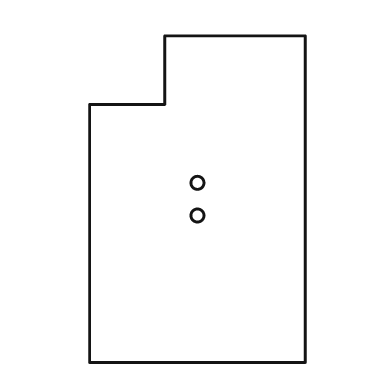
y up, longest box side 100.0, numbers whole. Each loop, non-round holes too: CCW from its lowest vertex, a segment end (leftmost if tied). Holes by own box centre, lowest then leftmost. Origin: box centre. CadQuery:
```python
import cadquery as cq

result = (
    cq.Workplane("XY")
    .moveTo(-33.0, -50.0)
    .lineTo(33.0, -50.0)
    .lineTo(33.0, 50.0)
    .lineTo(-10.0, 50.0)
    .lineTo(-10.0, 29.0)
    .lineTo(-33.0, 29.0)
    .close()
    .moveTo(0.0, -5.0)
    .circle(2.0)
    .moveTo(0.0, 5.0)
    .circle(2.0)
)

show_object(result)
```